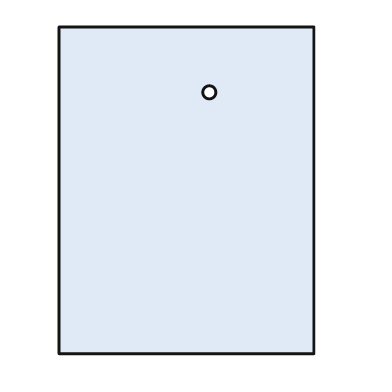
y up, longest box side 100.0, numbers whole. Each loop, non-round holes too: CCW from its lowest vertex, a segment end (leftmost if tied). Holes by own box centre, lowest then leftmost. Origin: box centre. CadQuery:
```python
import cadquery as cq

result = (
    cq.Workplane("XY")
    .moveTo(-39.0, -50.0)
    .lineTo(39.0, -50.0)
    .lineTo(39.0, 50.0)
    .lineTo(-39.0, 50.0)
    .close()
    .moveTo(7.0, 30.0)
    .circle(2.0)
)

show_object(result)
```